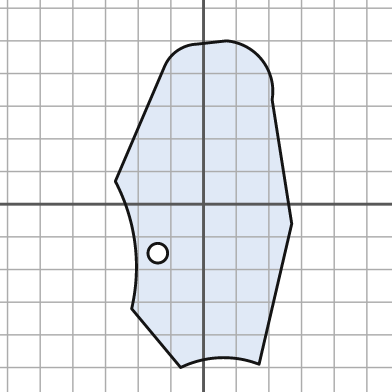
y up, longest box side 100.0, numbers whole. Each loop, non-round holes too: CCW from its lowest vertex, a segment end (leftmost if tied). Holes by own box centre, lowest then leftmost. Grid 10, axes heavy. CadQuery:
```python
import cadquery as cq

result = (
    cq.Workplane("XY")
    .moveTo(-7.0, -50.0)
    .threePointArc((5.0, -47.0), (17.0, -49.0))
    .lineTo(27.0, -6.0)
    .lineTo(21.0, 32.0)
    .threePointArc((18.0, 44.0), (7.0, 50.0))
    .lineTo(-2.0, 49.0)
    .threePointArc((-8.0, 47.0), (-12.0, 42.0))
    .lineTo(-27.0, 7.0)
    .threePointArc((-21.0, -12.0), (-22.0, -32.0))
    .close()
    .moveTo(-14.0, -15.0)
    .circle(3.0)
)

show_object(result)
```